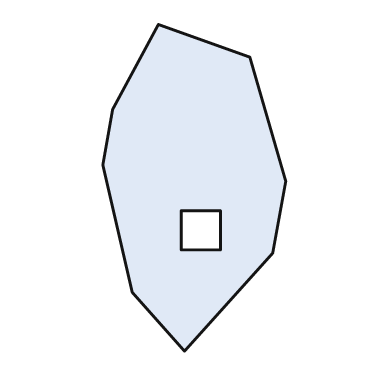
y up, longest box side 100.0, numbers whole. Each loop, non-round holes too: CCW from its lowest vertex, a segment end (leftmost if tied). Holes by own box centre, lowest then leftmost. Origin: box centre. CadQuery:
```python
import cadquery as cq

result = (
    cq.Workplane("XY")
    .moveTo(-3.0, -50.0)
    .lineTo(24.0, -20.0)
    .lineTo(28.0, 2.0)
    .lineTo(17.0, 40.0)
    .lineTo(-11.0, 50.0)
    .lineTo(-25.0, 24.0)
    .lineTo(-28.0, 7.0)
    .lineTo(-19.0, -32.0)
    .close()
    .moveTo(-4.0, -19.0)
    .lineTo(8.0, -19.0)
    .lineTo(8.0, -7.0)
    .lineTo(-4.0, -7.0)
    .close()
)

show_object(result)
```